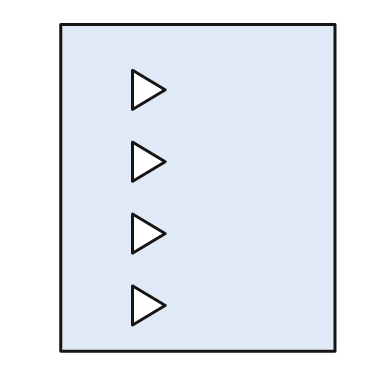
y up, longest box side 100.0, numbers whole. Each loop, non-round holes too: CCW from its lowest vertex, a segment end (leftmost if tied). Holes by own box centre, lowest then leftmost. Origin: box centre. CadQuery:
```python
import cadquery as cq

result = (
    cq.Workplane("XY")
    .moveTo(-42.0, -50.0)
    .lineTo(42.0, -50.0)
    .lineTo(42.0, 50.0)
    .lineTo(-42.0, 50.0)
    .close()
    .moveTo(-20.0, -42.0)
    .lineTo(-10.0, -36.0)
    .lineTo(-20.0, -30.0)
    .close()
    .moveTo(-20.0, -20.0)
    .lineTo(-10.0, -14.0)
    .lineTo(-20.0, -8.0)
    .close()
    .moveTo(-20.0, 2.0)
    .lineTo(-10.0, 8.0)
    .lineTo(-20.0, 14.0)
    .close()
    .moveTo(-20.0, 24.0)
    .lineTo(-10.0, 30.0)
    .lineTo(-20.0, 36.0)
    .close()
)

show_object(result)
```